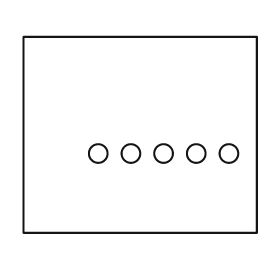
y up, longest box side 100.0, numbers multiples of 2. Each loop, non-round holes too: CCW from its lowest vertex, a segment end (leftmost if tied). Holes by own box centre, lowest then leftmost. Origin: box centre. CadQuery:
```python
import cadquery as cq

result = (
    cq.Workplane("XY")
    .moveTo(-50.0, -42.0)
    .lineTo(50.0, -42.0)
    .lineTo(50.0, 42.0)
    .lineTo(-50.0, 42.0)
    .close()
    .moveTo(-18.0, -8.0)
    .circle(4.0)
    .moveTo(-4.0, -8.0)
    .circle(4.0)
    .moveTo(10.0, -8.0)
    .circle(4.0)
    .moveTo(24.0, -8.0)
    .circle(4.0)
    .moveTo(38.0, -8.0)
    .circle(4.0)
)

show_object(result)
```